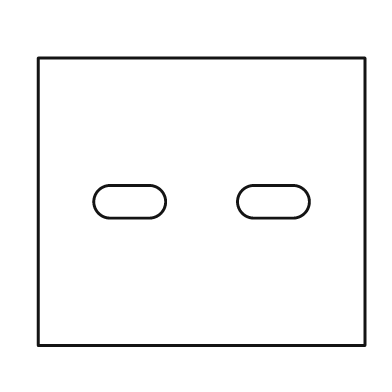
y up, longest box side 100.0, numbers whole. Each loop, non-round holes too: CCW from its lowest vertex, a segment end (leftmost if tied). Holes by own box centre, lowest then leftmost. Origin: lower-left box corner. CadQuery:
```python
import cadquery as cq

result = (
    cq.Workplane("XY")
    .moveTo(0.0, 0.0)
    .lineTo(100.0, 0.0)
    .lineTo(100.0, 88.0)
    .lineTo(0.0, 88.0)
    .close()
    .moveTo(22.0, 39.0)
    .lineTo(34.0, 39.0)
    .threePointArc((39.0, 44.0), (34.0, 49.0))
    .lineTo(22.0, 49.0)
    .threePointArc((17.0, 44.0), (22.0, 39.0))
    .close()
    .moveTo(66.0, 39.0)
    .lineTo(78.0, 39.0)
    .threePointArc((83.0, 44.0), (78.0, 49.0))
    .lineTo(66.0, 49.0)
    .threePointArc((61.0, 44.0), (66.0, 39.0))
    .close()
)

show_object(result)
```